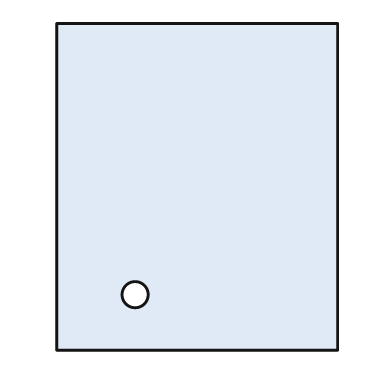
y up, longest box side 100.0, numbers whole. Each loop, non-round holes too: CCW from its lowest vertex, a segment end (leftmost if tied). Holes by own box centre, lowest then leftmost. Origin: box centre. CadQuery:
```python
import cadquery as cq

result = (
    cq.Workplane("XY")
    .moveTo(-43.0, -50.0)
    .lineTo(43.0, -50.0)
    .lineTo(43.0, 50.0)
    .lineTo(-43.0, 50.0)
    .close()
    .moveTo(-19.0, -33.0)
    .circle(4.0)
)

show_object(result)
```